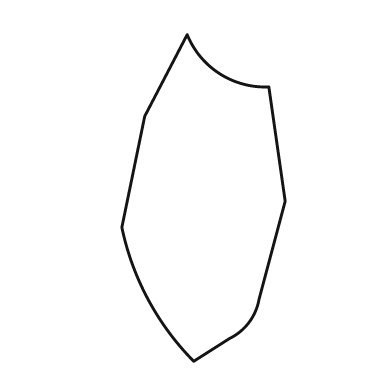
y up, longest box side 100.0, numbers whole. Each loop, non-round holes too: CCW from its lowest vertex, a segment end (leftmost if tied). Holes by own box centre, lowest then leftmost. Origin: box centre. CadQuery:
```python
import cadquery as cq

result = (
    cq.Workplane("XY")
    .moveTo(-3.0, -50.0)
    .lineTo(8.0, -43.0)
    .threePointArc((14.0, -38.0), (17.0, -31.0))
    .lineTo(25.0, -1.0)
    .lineTo(20.0, 34.0)
    .threePointArc((5.0, 38.0), (-5.0, 50.0))
    .lineTo(-18.0, 25.0)
    .lineTo(-25.0, -9.0)
    .threePointArc((-17.0, -31.0), (-3.0, -50.0))
    .close()
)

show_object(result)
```